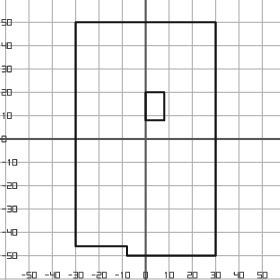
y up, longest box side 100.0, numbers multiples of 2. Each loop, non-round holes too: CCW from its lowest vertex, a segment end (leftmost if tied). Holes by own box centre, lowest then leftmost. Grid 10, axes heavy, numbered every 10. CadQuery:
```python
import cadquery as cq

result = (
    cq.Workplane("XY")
    .moveTo(-8.0, -50.0)
    .lineTo(30.0, -50.0)
    .lineTo(30.0, 50.0)
    .lineTo(-30.0, 50.0)
    .lineTo(-30.0, -46.0)
    .lineTo(-8.0, -46.0)
    .close()
    .moveTo(0.0, 8.0)
    .lineTo(8.0, 8.0)
    .lineTo(8.0, 20.0)
    .lineTo(0.0, 20.0)
    .close()
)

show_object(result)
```